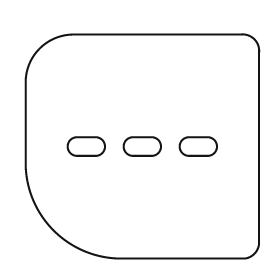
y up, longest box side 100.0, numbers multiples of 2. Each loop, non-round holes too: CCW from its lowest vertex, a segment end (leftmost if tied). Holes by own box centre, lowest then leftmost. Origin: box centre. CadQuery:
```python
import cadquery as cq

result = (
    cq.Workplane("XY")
    .moveTo(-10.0, -48.0)
    .lineTo(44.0, -48.0)
    .threePointArc((48.0, -46.0), (50.0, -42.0))
    .lineTo(50.0, 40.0)
    .threePointArc((48.0, 46.0), (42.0, 48.0))
    .lineTo(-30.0, 48.0)
    .threePointArc((-44.0, 42.0), (-50.0, 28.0))
    .lineTo(-50.0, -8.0)
    .threePointArc((-38.0, -36.0), (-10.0, -48.0))
    .close()
    .moveTo(-28.0, -4.0)
    .lineTo(-20.0, -4.0)
    .threePointArc((-16.0, 0.0), (-20.0, 4.0))
    .lineTo(-28.0, 4.0)
    .threePointArc((-32.0, 0.0), (-28.0, -4.0))
    .close()
    .moveTo(-4.0, -4.0)
    .lineTo(4.0, -4.0)
    .threePointArc((8.0, 0.0), (4.0, 4.0))
    .lineTo(-4.0, 4.0)
    .threePointArc((-8.0, 0.0), (-4.0, -4.0))
    .close()
    .moveTo(20.0, -4.0)
    .lineTo(28.0, -4.0)
    .threePointArc((32.0, 0.0), (28.0, 4.0))
    .lineTo(20.0, 4.0)
    .threePointArc((16.0, 0.0), (20.0, -4.0))
    .close()
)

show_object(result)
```